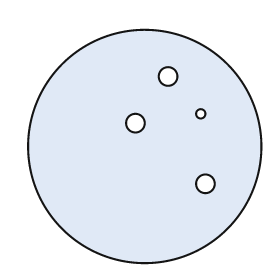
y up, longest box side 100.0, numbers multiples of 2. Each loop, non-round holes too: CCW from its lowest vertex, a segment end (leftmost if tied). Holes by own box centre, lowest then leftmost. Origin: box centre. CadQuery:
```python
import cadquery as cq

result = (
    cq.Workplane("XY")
    .moveTo(0.0, 0.0)
    .circle(50.0)
    .moveTo(26.0, -16.0)
    .circle(4.0)
    .moveTo(-4.0, 10.0)
    .circle(4.0)
    .moveTo(24.0, 14.0)
    .circle(2.0)
    .moveTo(10.0, 30.0)
    .circle(4.0)
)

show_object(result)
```